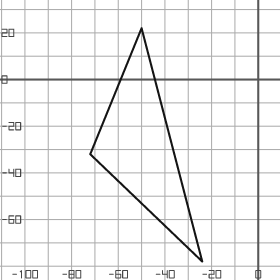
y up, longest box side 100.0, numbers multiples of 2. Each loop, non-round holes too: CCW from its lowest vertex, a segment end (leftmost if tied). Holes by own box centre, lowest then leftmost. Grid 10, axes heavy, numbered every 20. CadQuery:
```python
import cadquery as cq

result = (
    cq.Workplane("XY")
    .moveTo(-24.0, -78.0)
    .lineTo(-50.0, 22.0)
    .lineTo(-72.0, -32.0)
    .close()
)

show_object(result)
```